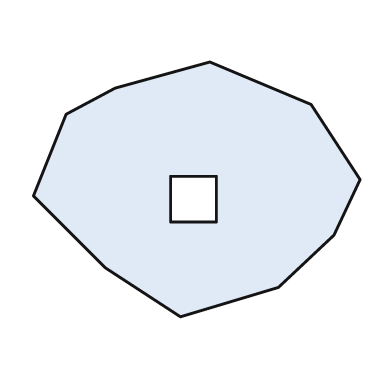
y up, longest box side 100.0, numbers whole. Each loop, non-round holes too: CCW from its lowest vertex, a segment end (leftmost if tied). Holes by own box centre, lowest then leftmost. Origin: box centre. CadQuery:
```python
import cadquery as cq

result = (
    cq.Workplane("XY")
    .moveTo(-5.0, -39.0)
    .lineTo(25.0, -30.0)
    .lineTo(42.0, -14.0)
    .lineTo(50.0, 3.0)
    .lineTo(35.0, 26.0)
    .lineTo(4.0, 39.0)
    .lineTo(-25.0, 31.0)
    .lineTo(-40.0, 23.0)
    .lineTo(-50.0, -2.0)
    .lineTo(-28.0, -24.0)
    .close()
    .moveTo(-8.0, -10.0)
    .lineTo(6.0, -10.0)
    .lineTo(6.0, 4.0)
    .lineTo(-8.0, 4.0)
    .close()
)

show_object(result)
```